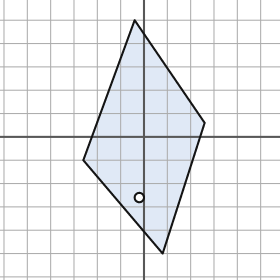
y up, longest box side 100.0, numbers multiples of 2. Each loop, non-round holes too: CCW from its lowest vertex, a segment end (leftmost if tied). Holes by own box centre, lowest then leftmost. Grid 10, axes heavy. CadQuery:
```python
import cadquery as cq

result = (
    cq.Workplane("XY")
    .moveTo(8.0, -50.0)
    .lineTo(26.0, 6.0)
    .lineTo(-4.0, 50.0)
    .lineTo(-26.0, -10.0)
    .close()
    .moveTo(-2.0, -26.0)
    .circle(2.0)
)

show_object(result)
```